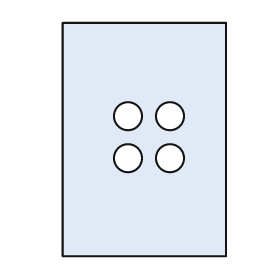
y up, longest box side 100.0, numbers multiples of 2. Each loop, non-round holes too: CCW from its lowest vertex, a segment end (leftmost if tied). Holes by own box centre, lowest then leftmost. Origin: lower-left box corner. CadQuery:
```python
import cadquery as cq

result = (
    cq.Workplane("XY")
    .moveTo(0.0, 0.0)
    .lineTo(70.0, 0.0)
    .lineTo(70.0, 100.0)
    .lineTo(0.0, 100.0)
    .close()
    .moveTo(28.0, 42.0)
    .circle(6.0)
    .moveTo(46.0, 42.0)
    .circle(6.0)
    .moveTo(28.0, 60.0)
    .circle(6.0)
    .moveTo(46.0, 60.0)
    .circle(6.0)
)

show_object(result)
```